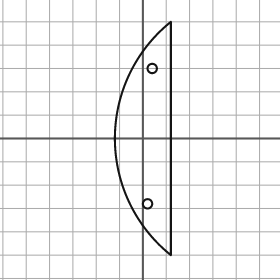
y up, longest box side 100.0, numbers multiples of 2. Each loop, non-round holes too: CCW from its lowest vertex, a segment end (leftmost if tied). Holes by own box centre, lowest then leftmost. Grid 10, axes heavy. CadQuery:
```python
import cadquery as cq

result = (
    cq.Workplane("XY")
    .moveTo(12.0, -50.0)
    .lineTo(12.0, 50.0)
    .threePointArc((-12.0, 0.0), (12.0, -50.0))
    .close()
    .moveTo(2.0, -28.0)
    .circle(2.0)
    .moveTo(4.0, 30.0)
    .circle(2.0)
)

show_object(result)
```